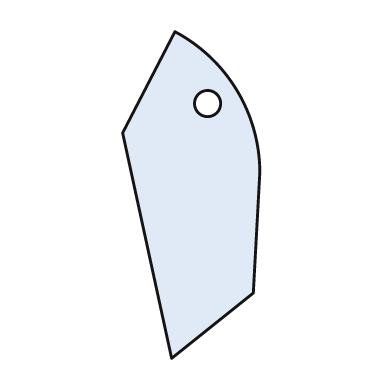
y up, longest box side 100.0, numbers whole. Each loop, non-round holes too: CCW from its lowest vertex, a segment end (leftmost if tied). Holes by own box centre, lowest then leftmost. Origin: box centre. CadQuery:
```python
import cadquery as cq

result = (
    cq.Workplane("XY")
    .moveTo(-6.0, -50.0)
    .lineTo(19.0, -30.0)
    .lineTo(21.0, 7.0)
    .threePointArc((14.0, 32.0), (-5.0, 50.0))
    .lineTo(-21.0, 19.0)
    .close()
    .moveTo(5.0, 28.0)
    .circle(4.0)
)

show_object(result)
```